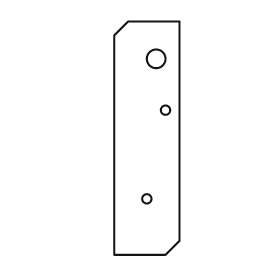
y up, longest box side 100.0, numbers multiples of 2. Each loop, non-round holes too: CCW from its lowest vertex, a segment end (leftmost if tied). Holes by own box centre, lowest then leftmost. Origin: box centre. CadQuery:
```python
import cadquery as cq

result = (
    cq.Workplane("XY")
    .moveTo(-14.0, -50.0)
    .lineTo(8.0, -50.0)
    .lineTo(14.0, -44.0)
    .lineTo(14.0, 50.0)
    .lineTo(-8.0, 50.0)
    .lineTo(-14.0, 44.0)
    .close()
    .moveTo(0.0, -26.0)
    .circle(2.0)
    .moveTo(8.0, 12.0)
    .circle(2.0)
    .moveTo(4.0, 34.0)
    .circle(4.0)
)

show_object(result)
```